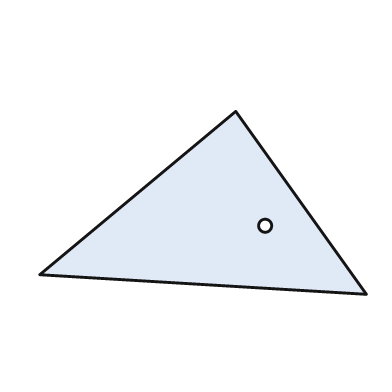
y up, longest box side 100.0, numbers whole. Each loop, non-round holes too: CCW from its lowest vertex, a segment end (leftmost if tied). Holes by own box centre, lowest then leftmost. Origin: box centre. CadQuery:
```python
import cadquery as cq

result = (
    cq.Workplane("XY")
    .moveTo(50.0, -28.0)
    .lineTo(10.0, 28.0)
    .lineTo(-50.0, -22.0)
    .close()
    .moveTo(19.0, -7.0)
    .circle(2.0)
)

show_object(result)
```